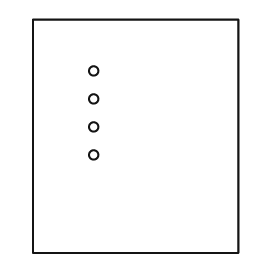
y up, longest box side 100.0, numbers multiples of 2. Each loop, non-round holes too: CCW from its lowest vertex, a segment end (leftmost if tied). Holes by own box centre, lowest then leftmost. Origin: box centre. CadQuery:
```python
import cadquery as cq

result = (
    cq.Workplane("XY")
    .moveTo(-44.0, -50.0)
    .lineTo(44.0, -50.0)
    .lineTo(44.0, 50.0)
    .lineTo(-44.0, 50.0)
    .close()
    .moveTo(-18.0, -8.0)
    .circle(2.0)
    .moveTo(-18.0, 4.0)
    .circle(2.0)
    .moveTo(-18.0, 16.0)
    .circle(2.0)
    .moveTo(-18.0, 28.0)
    .circle(2.0)
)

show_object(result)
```